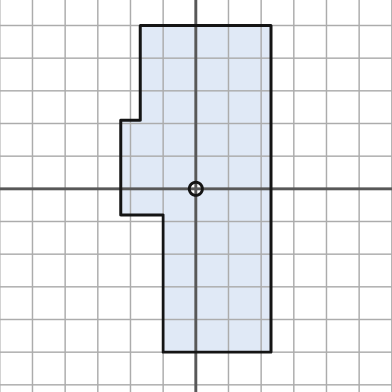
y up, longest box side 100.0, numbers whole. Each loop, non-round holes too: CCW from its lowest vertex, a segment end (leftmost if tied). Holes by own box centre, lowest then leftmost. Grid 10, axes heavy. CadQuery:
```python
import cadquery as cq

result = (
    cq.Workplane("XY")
    .moveTo(-10.0, -50.0)
    .lineTo(23.0, -50.0)
    .lineTo(23.0, 50.0)
    .lineTo(-17.0, 50.0)
    .lineTo(-17.0, 21.0)
    .lineTo(-23.0, 21.0)
    .lineTo(-23.0, -8.0)
    .lineTo(-10.0, -8.0)
    .close()
    .moveTo(0.0, 0.0)
    .circle(2.0)
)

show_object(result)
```